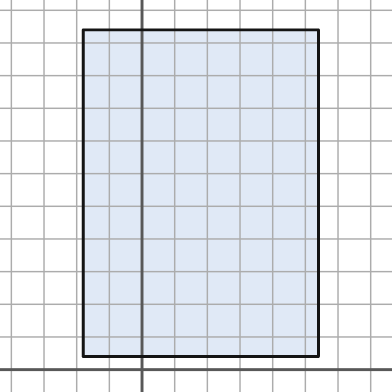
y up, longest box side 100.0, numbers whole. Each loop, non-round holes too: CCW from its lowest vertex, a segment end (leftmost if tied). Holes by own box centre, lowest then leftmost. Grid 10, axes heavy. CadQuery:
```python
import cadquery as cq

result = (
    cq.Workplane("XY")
    .moveTo(-18.0, 4.0)
    .lineTo(54.0, 4.0)
    .lineTo(54.0, 104.0)
    .lineTo(-18.0, 104.0)
    .close()
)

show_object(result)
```